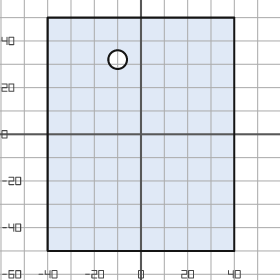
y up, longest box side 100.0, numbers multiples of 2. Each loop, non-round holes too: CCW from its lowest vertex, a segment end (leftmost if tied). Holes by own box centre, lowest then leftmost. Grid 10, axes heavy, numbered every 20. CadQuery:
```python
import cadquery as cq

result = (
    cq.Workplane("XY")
    .moveTo(-40.0, -50.0)
    .lineTo(40.0, -50.0)
    .lineTo(40.0, 50.0)
    .lineTo(-40.0, 50.0)
    .close()
    .moveTo(-10.0, 32.0)
    .circle(4.0)
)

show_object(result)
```